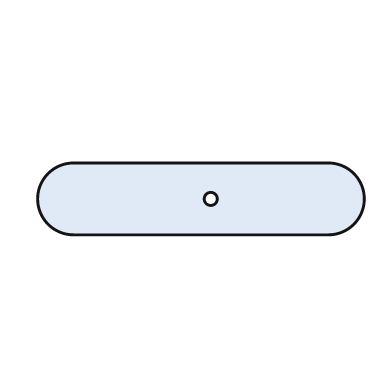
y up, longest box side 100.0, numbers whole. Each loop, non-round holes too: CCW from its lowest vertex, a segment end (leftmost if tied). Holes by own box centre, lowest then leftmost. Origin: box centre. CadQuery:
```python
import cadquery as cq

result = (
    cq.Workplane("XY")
    .moveTo(-39.0, -11.0)
    .lineTo(39.0, -11.0)
    .threePointArc((50.0, 0.0), (39.0, 11.0))
    .lineTo(-39.0, 11.0)
    .threePointArc((-50.0, 0.0), (-39.0, -11.0))
    .close()
    .moveTo(3.0, 0.0)
    .circle(2.0)
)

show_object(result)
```